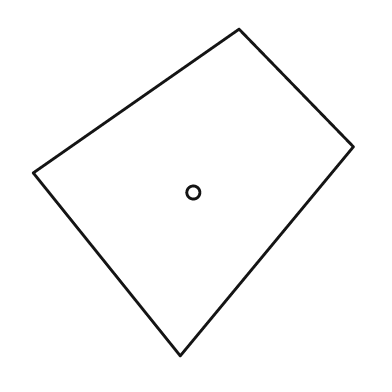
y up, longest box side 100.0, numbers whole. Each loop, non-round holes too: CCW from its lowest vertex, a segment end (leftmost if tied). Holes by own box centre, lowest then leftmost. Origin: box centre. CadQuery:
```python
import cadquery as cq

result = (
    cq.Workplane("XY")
    .moveTo(-4.0, -50.0)
    .lineTo(49.0, 14.0)
    .lineTo(14.0, 50.0)
    .lineTo(-49.0, 6.0)
    .close()
    .moveTo(0.0, 0.0)
    .circle(2.0)
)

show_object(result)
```